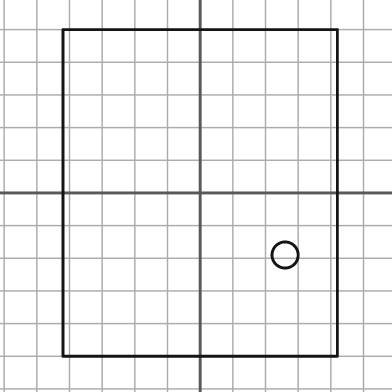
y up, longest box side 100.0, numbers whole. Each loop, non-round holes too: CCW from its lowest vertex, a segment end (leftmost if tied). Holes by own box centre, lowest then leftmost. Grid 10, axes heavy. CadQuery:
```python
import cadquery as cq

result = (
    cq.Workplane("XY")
    .moveTo(-42.0, -50.0)
    .lineTo(42.0, -50.0)
    .lineTo(42.0, 50.0)
    .lineTo(-42.0, 50.0)
    .close()
    .moveTo(26.0, -19.0)
    .circle(4.0)
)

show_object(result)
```